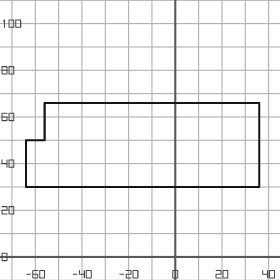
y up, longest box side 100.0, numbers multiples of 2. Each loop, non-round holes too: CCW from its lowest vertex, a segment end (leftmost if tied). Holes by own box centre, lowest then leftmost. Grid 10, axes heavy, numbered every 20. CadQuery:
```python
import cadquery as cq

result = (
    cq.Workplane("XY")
    .moveTo(-64.0, 30.0)
    .lineTo(36.0, 30.0)
    .lineTo(36.0, 66.0)
    .lineTo(-56.0, 66.0)
    .lineTo(-56.0, 50.0)
    .lineTo(-64.0, 50.0)
    .close()
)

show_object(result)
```